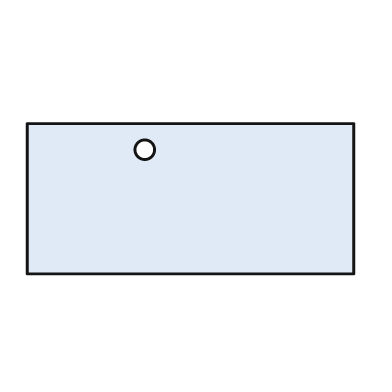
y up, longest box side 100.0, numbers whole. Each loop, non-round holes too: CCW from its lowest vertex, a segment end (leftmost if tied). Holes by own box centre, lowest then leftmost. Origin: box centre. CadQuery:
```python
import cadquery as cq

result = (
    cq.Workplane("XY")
    .moveTo(-50.0, -23.0)
    .lineTo(50.0, -23.0)
    .lineTo(50.0, 23.0)
    .lineTo(-50.0, 23.0)
    .close()
    .moveTo(-14.0, 15.0)
    .circle(3.0)
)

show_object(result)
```